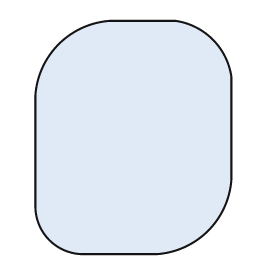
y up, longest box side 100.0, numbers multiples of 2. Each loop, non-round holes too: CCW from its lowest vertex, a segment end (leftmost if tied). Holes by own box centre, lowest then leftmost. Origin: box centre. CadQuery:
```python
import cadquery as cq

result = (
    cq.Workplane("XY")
    .moveTo(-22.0, -50.0)
    .lineTo(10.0, -50.0)
    .threePointArc((32.0, -40.0), (42.0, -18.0))
    .lineTo(42.0, 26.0)
    .threePointArc((34.0, 42.0), (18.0, 50.0))
    .lineTo(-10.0, 50.0)
    .threePointArc((-32.0, 40.0), (-42.0, 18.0))
    .lineTo(-42.0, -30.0)
    .threePointArc((-36.0, -44.0), (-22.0, -50.0))
    .close()
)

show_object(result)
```